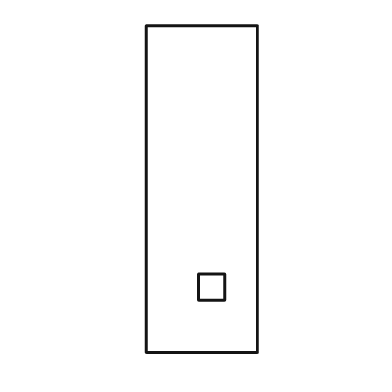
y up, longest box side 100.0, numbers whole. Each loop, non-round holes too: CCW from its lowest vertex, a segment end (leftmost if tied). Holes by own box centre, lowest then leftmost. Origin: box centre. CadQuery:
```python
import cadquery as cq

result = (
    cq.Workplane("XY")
    .moveTo(-17.0, -50.0)
    .lineTo(17.0, -50.0)
    .lineTo(17.0, 50.0)
    .lineTo(-17.0, 50.0)
    .close()
    .moveTo(-1.0, -34.0)
    .lineTo(7.0, -34.0)
    .lineTo(7.0, -26.0)
    .lineTo(-1.0, -26.0)
    .close()
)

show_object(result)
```